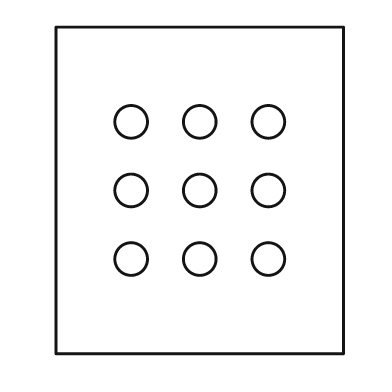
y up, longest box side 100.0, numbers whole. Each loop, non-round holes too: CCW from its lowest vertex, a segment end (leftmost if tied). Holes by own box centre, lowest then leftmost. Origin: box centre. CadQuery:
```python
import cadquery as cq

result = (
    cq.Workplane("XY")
    .moveTo(-44.0, -50.0)
    .lineTo(44.0, -50.0)
    .lineTo(44.0, 50.0)
    .lineTo(-44.0, 50.0)
    .close()
    .moveTo(-21.0, -21.0)
    .circle(5.0)
    .moveTo(0.0, -21.0)
    .circle(5.0)
    .moveTo(21.0, -21.0)
    .circle(5.0)
    .moveTo(-21.0, 0.0)
    .circle(5.0)
    .moveTo(0.0, 0.0)
    .circle(5.0)
    .moveTo(21.0, 0.0)
    .circle(5.0)
    .moveTo(-21.0, 21.0)
    .circle(5.0)
    .moveTo(0.0, 21.0)
    .circle(5.0)
    .moveTo(21.0, 21.0)
    .circle(5.0)
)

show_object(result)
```